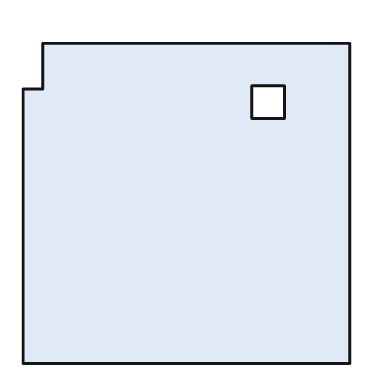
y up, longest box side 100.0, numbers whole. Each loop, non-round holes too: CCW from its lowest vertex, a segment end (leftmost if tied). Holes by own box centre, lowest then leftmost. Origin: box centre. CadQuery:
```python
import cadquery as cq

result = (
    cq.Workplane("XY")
    .moveTo(-50.0, -49.0)
    .lineTo(50.0, -49.0)
    .lineTo(50.0, 49.0)
    .lineTo(-44.0, 49.0)
    .lineTo(-44.0, 35.0)
    .lineTo(-50.0, 35.0)
    .close()
    .moveTo(20.0, 26.0)
    .lineTo(30.0, 26.0)
    .lineTo(30.0, 36.0)
    .lineTo(20.0, 36.0)
    .close()
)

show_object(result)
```